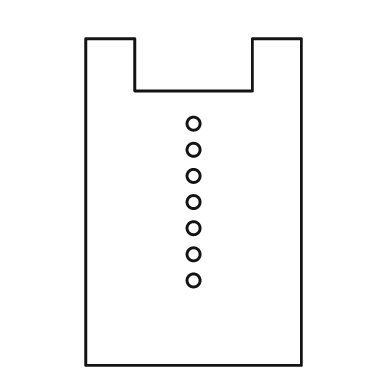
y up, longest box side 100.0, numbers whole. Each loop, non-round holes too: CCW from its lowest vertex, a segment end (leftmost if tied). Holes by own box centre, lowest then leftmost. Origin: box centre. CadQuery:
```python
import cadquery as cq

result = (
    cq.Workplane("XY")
    .moveTo(-33.0, -50.0)
    .lineTo(33.0, -50.0)
    .lineTo(33.0, 50.0)
    .lineTo(18.0, 50.0)
    .lineTo(18.0, 34.0)
    .lineTo(-18.0, 34.0)
    .lineTo(-18.0, 50.0)
    .lineTo(-33.0, 50.0)
    .close()
    .moveTo(0.0, -24.0)
    .circle(2.0)
    .moveTo(0.0, -16.0)
    .circle(2.0)
    .moveTo(0.0, -8.0)
    .circle(2.0)
    .moveTo(0.0, 0.0)
    .circle(2.0)
    .moveTo(0.0, 8.0)
    .circle(2.0)
    .moveTo(0.0, 16.0)
    .circle(2.0)
    .moveTo(0.0, 24.0)
    .circle(2.0)
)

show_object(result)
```